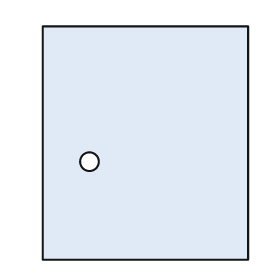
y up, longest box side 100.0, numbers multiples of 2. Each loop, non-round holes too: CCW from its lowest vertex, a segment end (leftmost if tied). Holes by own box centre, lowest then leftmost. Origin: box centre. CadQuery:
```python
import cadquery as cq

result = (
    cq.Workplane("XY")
    .moveTo(-44.0, -50.0)
    .lineTo(44.0, -50.0)
    .lineTo(44.0, 50.0)
    .lineTo(-44.0, 50.0)
    .close()
    .moveTo(-24.0, -8.0)
    .circle(4.0)
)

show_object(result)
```